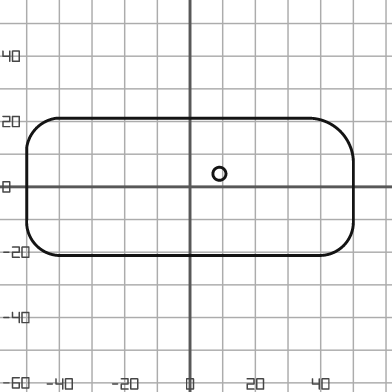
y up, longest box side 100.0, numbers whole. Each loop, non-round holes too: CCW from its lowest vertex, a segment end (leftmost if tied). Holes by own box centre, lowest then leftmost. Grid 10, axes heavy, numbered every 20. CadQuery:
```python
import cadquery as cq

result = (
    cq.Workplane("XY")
    .moveTo(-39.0, -21.0)
    .lineTo(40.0, -21.0)
    .threePointArc((47.0, -18.0), (50.0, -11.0))
    .lineTo(50.0, 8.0)
    .threePointArc((46.0, 17.0), (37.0, 21.0))
    .lineTo(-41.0, 21.0)
    .threePointArc((-47.0, 18.0), (-50.0, 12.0))
    .lineTo(-50.0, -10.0)
    .threePointArc((-47.0, -18.0), (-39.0, -21.0))
    .close()
    .moveTo(9.0, 4.0)
    .circle(2.0)
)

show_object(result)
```